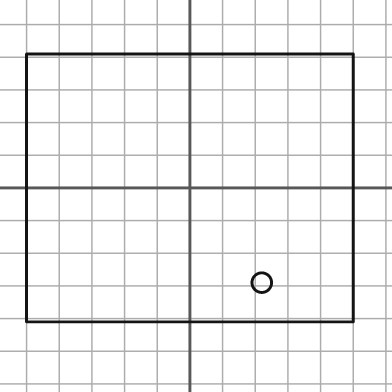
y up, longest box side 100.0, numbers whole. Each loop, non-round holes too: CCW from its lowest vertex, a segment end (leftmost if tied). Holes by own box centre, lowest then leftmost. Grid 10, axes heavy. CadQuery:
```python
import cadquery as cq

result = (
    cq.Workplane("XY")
    .moveTo(-50.0, -41.0)
    .lineTo(50.0, -41.0)
    .lineTo(50.0, 41.0)
    .lineTo(-50.0, 41.0)
    .close()
    .moveTo(22.0, -29.0)
    .circle(3.0)
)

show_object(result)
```